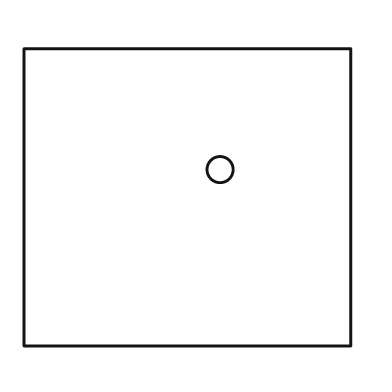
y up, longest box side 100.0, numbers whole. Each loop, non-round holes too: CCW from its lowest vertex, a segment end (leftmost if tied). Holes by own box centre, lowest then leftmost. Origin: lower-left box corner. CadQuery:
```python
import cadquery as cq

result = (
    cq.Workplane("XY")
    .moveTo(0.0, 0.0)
    .lineTo(100.0, 0.0)
    .lineTo(100.0, 91.0)
    .lineTo(0.0, 91.0)
    .close()
    .moveTo(60.0, 54.0)
    .circle(4.0)
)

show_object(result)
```